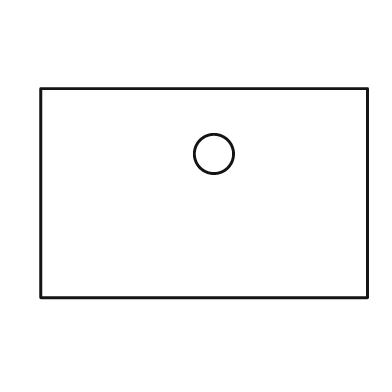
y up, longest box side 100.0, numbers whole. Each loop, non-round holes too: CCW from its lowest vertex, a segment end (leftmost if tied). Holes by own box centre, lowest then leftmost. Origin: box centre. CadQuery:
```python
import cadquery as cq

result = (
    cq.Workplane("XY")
    .moveTo(-50.0, -32.0)
    .lineTo(50.0, -32.0)
    .lineTo(50.0, 32.0)
    .lineTo(-50.0, 32.0)
    .close()
    .moveTo(3.0, 12.0)
    .circle(6.0)
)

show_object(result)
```